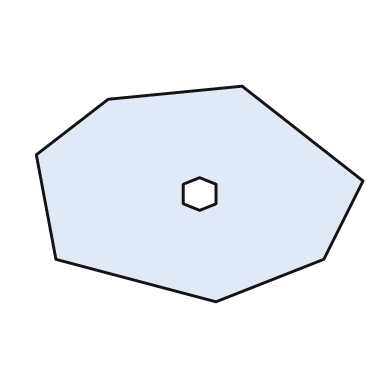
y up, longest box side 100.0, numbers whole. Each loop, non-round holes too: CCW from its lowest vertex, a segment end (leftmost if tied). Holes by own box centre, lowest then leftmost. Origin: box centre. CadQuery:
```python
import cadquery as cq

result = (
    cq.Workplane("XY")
    .moveTo(5.0, -33.0)
    .lineTo(38.0, -20.0)
    .lineTo(50.0, 4.0)
    .lineTo(13.0, 33.0)
    .lineTo(-28.0, 29.0)
    .lineTo(-50.0, 12.0)
    .lineTo(-44.0, -20.0)
    .close()
    .moveTo(0.0, -5.0)
    .lineTo(5.0, -3.0)
    .lineTo(5.0, 3.0)
    .lineTo(0.0, 5.0)
    .lineTo(-5.0, 3.0)
    .lineTo(-5.0, -3.0)
    .close()
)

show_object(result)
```